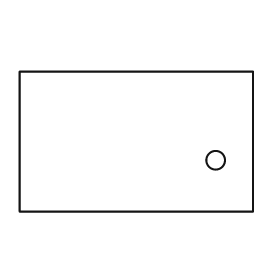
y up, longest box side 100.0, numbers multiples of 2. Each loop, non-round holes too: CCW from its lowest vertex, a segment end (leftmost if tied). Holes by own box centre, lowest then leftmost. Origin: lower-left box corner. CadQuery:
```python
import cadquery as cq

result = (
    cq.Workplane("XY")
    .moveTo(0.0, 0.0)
    .lineTo(100.0, 0.0)
    .lineTo(100.0, 60.0)
    .lineTo(0.0, 60.0)
    .close()
    .moveTo(84.0, 22.0)
    .circle(4.0)
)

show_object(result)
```